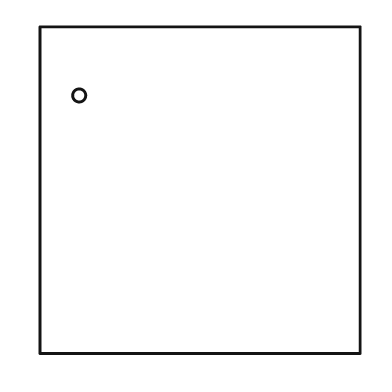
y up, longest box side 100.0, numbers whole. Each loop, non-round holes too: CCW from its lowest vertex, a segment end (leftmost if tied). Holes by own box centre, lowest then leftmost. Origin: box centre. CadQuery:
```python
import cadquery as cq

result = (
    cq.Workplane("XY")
    .moveTo(-49.0, -50.0)
    .lineTo(49.0, -50.0)
    .lineTo(49.0, 50.0)
    .lineTo(-49.0, 50.0)
    .close()
    .moveTo(-37.0, 29.0)
    .circle(2.0)
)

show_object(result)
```